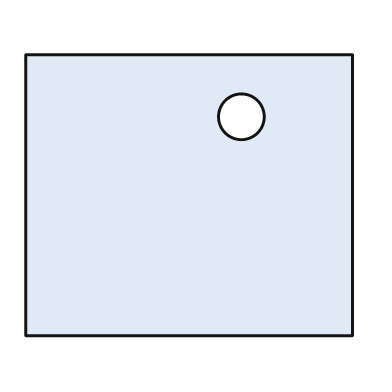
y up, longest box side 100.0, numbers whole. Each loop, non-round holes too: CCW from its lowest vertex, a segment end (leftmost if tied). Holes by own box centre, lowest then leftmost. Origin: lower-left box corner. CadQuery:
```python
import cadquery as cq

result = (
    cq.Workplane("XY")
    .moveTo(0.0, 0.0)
    .lineTo(100.0, 0.0)
    .lineTo(100.0, 86.0)
    .lineTo(0.0, 86.0)
    .close()
    .moveTo(66.0, 67.0)
    .circle(7.0)
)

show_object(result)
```